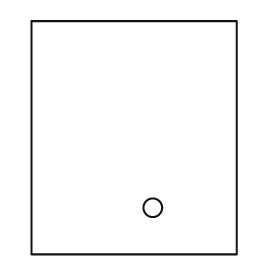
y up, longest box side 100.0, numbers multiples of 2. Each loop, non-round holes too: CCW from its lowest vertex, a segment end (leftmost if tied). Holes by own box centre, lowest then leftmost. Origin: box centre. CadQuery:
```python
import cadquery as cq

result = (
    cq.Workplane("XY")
    .moveTo(-44.0, -50.0)
    .lineTo(44.0, -50.0)
    .lineTo(44.0, 50.0)
    .lineTo(-44.0, 50.0)
    .close()
    .moveTo(8.0, -30.0)
    .circle(4.0)
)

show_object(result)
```